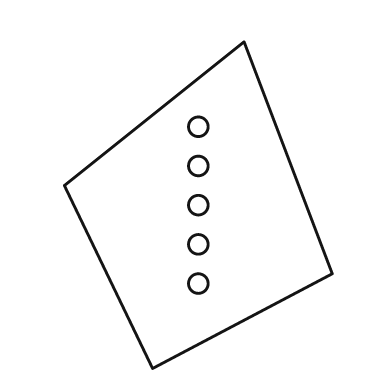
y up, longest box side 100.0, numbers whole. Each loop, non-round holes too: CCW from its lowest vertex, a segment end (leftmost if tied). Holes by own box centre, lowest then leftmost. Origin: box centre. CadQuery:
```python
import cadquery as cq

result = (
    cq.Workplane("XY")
    .moveTo(-14.0, -50.0)
    .lineTo(41.0, -21.0)
    .lineTo(14.0, 50.0)
    .lineTo(-41.0, 6.0)
    .close()
    .moveTo(0.0, -24.0)
    .circle(3.0)
    .moveTo(0.0, -12.0)
    .circle(3.0)
    .moveTo(0.0, 0.0)
    .circle(3.0)
    .moveTo(0.0, 12.0)
    .circle(3.0)
    .moveTo(0.0, 24.0)
    .circle(3.0)
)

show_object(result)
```